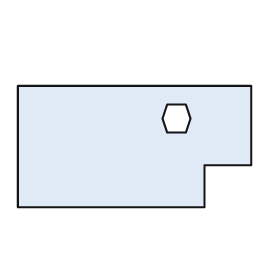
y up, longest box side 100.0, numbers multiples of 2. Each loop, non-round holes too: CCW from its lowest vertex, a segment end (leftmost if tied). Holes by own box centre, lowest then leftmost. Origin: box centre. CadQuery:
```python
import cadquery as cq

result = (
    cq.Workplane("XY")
    .moveTo(-50.0, -26.0)
    .lineTo(30.0, -26.0)
    .lineTo(30.0, -8.0)
    .lineTo(50.0, -8.0)
    .lineTo(50.0, 26.0)
    .lineTo(-50.0, 26.0)
    .close()
    .moveTo(14.0, 6.0)
    .lineTo(22.0, 6.0)
    .lineTo(24.0, 12.0)
    .lineTo(22.0, 18.0)
    .lineTo(14.0, 18.0)
    .lineTo(12.0, 12.0)
    .close()
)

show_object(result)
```